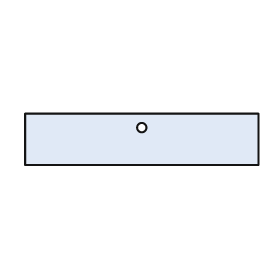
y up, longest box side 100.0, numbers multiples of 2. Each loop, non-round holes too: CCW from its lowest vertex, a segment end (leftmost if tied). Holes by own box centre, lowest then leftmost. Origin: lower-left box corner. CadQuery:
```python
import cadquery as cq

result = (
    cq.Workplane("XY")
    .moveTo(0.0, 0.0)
    .lineTo(100.0, 0.0)
    .lineTo(100.0, 22.0)
    .lineTo(0.0, 22.0)
    .close()
    .moveTo(50.0, 16.0)
    .circle(2.0)
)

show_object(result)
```